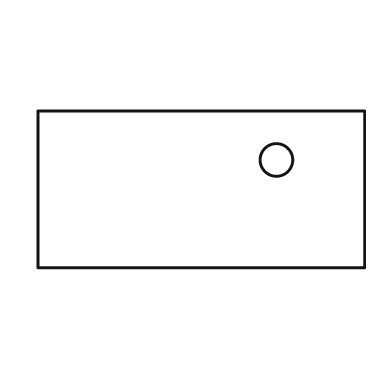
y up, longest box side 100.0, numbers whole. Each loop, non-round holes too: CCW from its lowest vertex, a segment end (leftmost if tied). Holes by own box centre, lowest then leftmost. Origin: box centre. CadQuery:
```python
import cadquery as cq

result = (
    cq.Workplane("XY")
    .moveTo(-50.0, -24.0)
    .lineTo(50.0, -24.0)
    .lineTo(50.0, 24.0)
    .lineTo(-50.0, 24.0)
    .close()
    .moveTo(23.0, 9.0)
    .circle(5.0)
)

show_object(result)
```